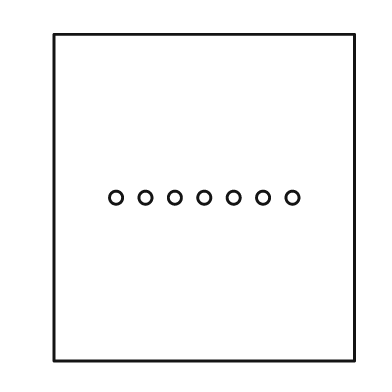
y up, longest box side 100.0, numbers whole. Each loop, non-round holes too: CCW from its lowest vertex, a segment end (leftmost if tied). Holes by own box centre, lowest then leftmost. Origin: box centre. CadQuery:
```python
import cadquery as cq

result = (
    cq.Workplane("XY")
    .moveTo(-46.0, -50.0)
    .lineTo(46.0, -50.0)
    .lineTo(46.0, 50.0)
    .lineTo(-46.0, 50.0)
    .close()
    .moveTo(-27.0, 0.0)
    .circle(2.0)
    .moveTo(-18.0, 0.0)
    .circle(2.0)
    .moveTo(-9.0, 0.0)
    .circle(2.0)
    .moveTo(0.0, 0.0)
    .circle(2.0)
    .moveTo(9.0, 0.0)
    .circle(2.0)
    .moveTo(18.0, 0.0)
    .circle(2.0)
    .moveTo(27.0, 0.0)
    .circle(2.0)
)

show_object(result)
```